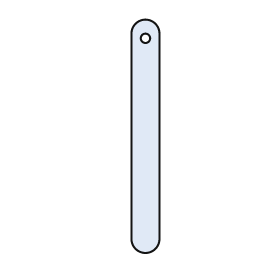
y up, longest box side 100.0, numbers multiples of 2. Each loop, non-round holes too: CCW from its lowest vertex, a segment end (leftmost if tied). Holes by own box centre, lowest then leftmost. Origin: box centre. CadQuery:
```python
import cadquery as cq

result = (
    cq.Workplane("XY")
    .moveTo(-6.0, -44.0)
    .threePointArc((0.0, -50.0), (6.0, -44.0))
    .lineTo(6.0, 44.0)
    .threePointArc((0.0, 50.0), (-6.0, 44.0))
    .close()
    .moveTo(0.0, 42.0)
    .circle(2.0)
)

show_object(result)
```